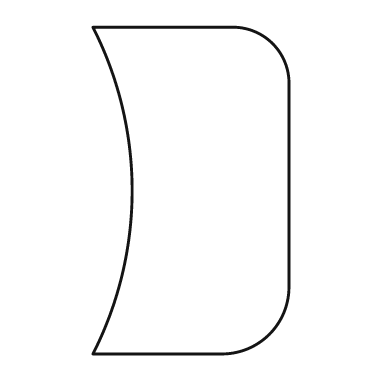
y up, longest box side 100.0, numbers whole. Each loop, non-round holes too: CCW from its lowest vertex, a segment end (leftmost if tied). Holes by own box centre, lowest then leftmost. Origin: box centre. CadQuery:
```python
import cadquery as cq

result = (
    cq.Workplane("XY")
    .moveTo(-30.0, -50.0)
    .lineTo(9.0, -50.0)
    .threePointArc((24.0, -44.0), (30.0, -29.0))
    .lineTo(30.0, 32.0)
    .threePointArc((25.0, 45.0), (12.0, 50.0))
    .lineTo(-30.0, 50.0)
    .threePointArc((-18.0, 0.0), (-30.0, -50.0))
    .close()
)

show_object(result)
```